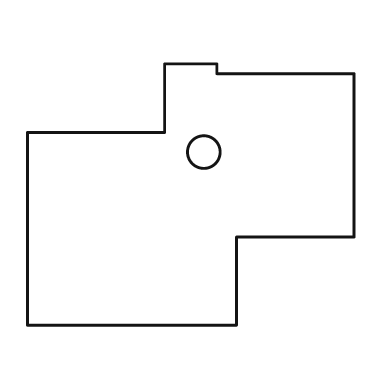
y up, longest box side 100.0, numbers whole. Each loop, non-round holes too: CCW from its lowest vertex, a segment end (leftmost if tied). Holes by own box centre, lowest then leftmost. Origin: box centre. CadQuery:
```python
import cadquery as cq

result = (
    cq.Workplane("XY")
    .moveTo(-50.0, -40.0)
    .lineTo(14.0, -40.0)
    .lineTo(14.0, -13.0)
    .lineTo(50.0, -13.0)
    .lineTo(50.0, 37.0)
    .lineTo(8.0, 37.0)
    .lineTo(8.0, 40.0)
    .lineTo(-8.0, 40.0)
    .lineTo(-8.0, 19.0)
    .lineTo(-50.0, 19.0)
    .close()
    .moveTo(4.0, 13.0)
    .circle(5.0)
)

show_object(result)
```